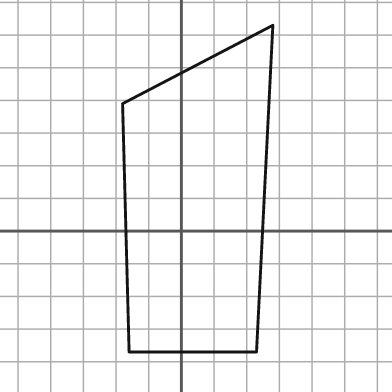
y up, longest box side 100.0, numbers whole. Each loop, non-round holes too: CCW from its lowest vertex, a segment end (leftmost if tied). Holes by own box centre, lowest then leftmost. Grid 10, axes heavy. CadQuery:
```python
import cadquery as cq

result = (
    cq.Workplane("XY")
    .moveTo(-16.0, -37.0)
    .lineTo(23.0, -37.0)
    .lineTo(28.0, 63.0)
    .lineTo(-18.0, 39.0)
    .close()
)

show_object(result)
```